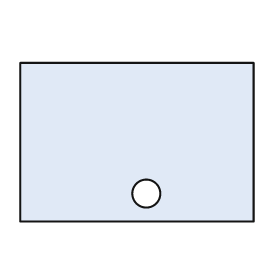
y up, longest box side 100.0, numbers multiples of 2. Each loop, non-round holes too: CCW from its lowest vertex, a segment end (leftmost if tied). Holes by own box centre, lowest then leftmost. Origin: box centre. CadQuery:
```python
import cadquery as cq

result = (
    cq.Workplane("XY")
    .moveTo(-50.0, -34.0)
    .lineTo(50.0, -34.0)
    .lineTo(50.0, 34.0)
    .lineTo(-50.0, 34.0)
    .close()
    .moveTo(4.0, -22.0)
    .circle(6.0)
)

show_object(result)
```